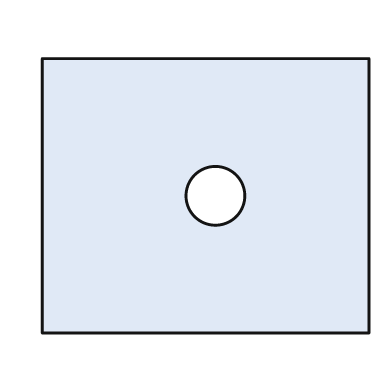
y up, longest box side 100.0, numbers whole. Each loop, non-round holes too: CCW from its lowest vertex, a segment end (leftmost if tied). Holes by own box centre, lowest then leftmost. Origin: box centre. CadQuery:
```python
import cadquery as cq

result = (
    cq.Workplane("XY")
    .moveTo(-50.0, -42.0)
    .lineTo(50.0, -42.0)
    .lineTo(50.0, 42.0)
    .lineTo(-50.0, 42.0)
    .close()
    .moveTo(3.0, 0.0)
    .circle(9.0)
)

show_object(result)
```